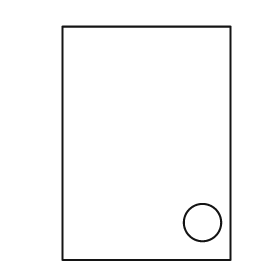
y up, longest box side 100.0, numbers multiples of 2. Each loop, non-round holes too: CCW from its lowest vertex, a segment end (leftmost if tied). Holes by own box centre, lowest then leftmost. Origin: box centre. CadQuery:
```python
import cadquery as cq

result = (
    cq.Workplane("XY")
    .moveTo(-36.0, -50.0)
    .lineTo(36.0, -50.0)
    .lineTo(36.0, 50.0)
    .lineTo(-36.0, 50.0)
    .close()
    .moveTo(24.0, -34.0)
    .circle(8.0)
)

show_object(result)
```